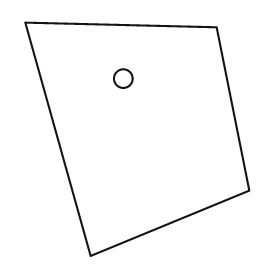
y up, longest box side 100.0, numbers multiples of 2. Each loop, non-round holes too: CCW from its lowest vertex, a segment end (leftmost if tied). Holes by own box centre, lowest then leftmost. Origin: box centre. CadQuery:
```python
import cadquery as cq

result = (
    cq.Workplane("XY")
    .moveTo(-20.0, -50.0)
    .lineTo(48.0, -22.0)
    .lineTo(34.0, 48.0)
    .lineTo(-48.0, 50.0)
    .close()
    .moveTo(-6.0, 26.0)
    .circle(4.0)
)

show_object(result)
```